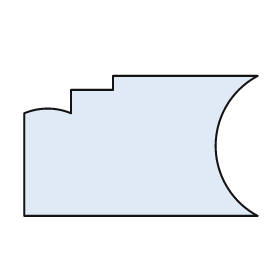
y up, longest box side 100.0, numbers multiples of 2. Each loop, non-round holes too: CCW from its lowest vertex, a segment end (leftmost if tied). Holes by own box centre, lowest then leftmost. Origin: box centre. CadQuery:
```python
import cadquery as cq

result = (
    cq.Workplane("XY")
    .moveTo(-50.0, -30.0)
    .lineTo(50.0, -30.0)
    .threePointArc((32.0, 0.0), (50.0, 30.0))
    .lineTo(-12.0, 30.0)
    .lineTo(-12.0, 24.0)
    .lineTo(-30.0, 24.0)
    .lineTo(-30.0, 14.0)
    .threePointArc((-40.0, 16.0), (-50.0, 14.0))
    .close()
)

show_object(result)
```